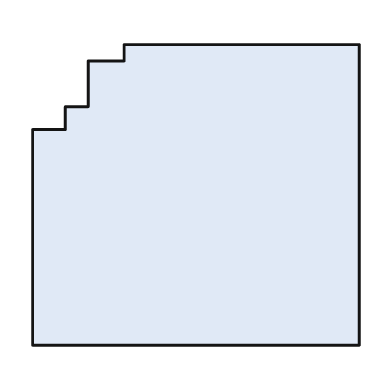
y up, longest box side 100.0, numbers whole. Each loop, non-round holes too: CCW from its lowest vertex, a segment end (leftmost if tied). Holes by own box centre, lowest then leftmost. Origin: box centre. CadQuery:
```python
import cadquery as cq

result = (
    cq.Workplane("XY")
    .moveTo(-50.0, -46.0)
    .lineTo(50.0, -46.0)
    .lineTo(50.0, 46.0)
    .lineTo(-22.0, 46.0)
    .lineTo(-22.0, 41.0)
    .lineTo(-33.0, 41.0)
    .lineTo(-33.0, 27.0)
    .lineTo(-40.0, 27.0)
    .lineTo(-40.0, 20.0)
    .lineTo(-50.0, 20.0)
    .close()
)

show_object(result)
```